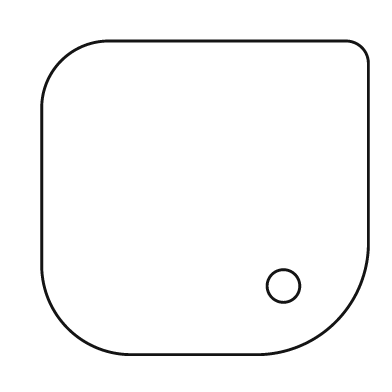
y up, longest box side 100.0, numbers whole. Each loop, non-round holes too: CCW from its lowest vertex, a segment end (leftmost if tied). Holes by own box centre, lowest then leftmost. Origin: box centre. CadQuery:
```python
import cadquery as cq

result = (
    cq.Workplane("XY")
    .moveTo(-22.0, -48.0)
    .lineTo(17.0, -48.0)
    .threePointArc((40.0, -38.0), (50.0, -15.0))
    .lineTo(50.0, 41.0)
    .threePointArc((48.0, 46.0), (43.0, 48.0))
    .lineTo(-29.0, 48.0)
    .threePointArc((-44.0, 42.0), (-50.0, 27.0))
    .lineTo(-50.0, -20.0)
    .threePointArc((-42.0, -40.0), (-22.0, -48.0))
    .close()
    .moveTo(24.0, -27.0)
    .circle(5.0)
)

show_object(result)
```